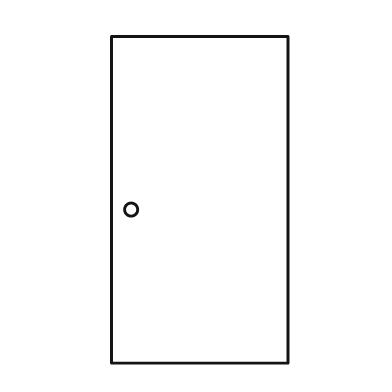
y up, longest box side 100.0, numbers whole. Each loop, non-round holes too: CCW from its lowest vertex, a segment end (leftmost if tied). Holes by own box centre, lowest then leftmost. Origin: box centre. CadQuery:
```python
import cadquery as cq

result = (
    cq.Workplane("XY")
    .moveTo(-27.0, -50.0)
    .lineTo(27.0, -50.0)
    .lineTo(27.0, 50.0)
    .lineTo(-27.0, 50.0)
    .close()
    .moveTo(-21.0, -3.0)
    .circle(2.0)
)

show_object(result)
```